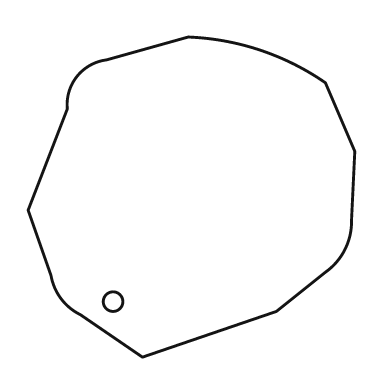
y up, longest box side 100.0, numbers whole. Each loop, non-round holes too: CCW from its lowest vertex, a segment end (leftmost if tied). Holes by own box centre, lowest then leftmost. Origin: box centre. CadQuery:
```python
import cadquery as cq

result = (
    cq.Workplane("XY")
    .moveTo(-15.0, -49.0)
    .lineTo(26.0, -35.0)
    .lineTo(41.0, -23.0)
    .threePointArc((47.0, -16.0), (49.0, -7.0))
    .lineTo(50.0, 14.0)
    .lineTo(41.0, 35.0)
    .threePointArc((21.0, 45.0), (-1.0, 49.0))
    .lineTo(-26.0, 42.0)
    .threePointArc((-35.0, 37.0), (-38.0, 27.0))
    .lineTo(-50.0, -4.0)
    .lineTo(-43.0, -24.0)
    .threePointArc((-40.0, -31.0), (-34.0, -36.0))
    .close()
    .moveTo(-24.0, -32.0)
    .circle(3.0)
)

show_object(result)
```